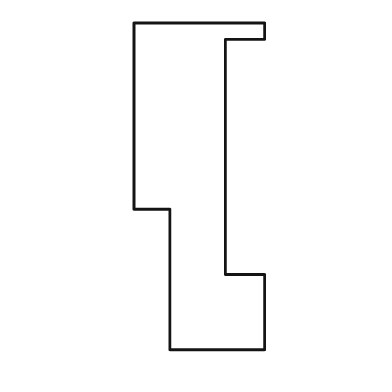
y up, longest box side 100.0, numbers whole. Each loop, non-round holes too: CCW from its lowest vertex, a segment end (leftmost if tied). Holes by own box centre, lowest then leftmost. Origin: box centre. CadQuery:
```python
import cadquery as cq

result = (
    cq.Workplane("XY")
    .moveTo(-9.0, -50.0)
    .lineTo(20.0, -50.0)
    .lineTo(20.0, -27.0)
    .lineTo(8.0, -27.0)
    .lineTo(8.0, 45.0)
    .lineTo(20.0, 45.0)
    .lineTo(20.0, 50.0)
    .lineTo(-20.0, 50.0)
    .lineTo(-20.0, -7.0)
    .lineTo(-9.0, -7.0)
    .close()
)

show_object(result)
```